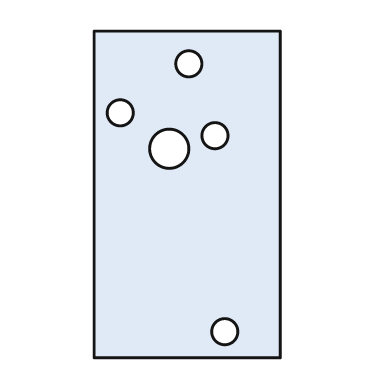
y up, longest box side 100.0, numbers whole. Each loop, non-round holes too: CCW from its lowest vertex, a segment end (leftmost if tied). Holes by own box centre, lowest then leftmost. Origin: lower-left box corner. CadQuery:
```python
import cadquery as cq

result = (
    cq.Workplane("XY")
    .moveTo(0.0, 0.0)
    .lineTo(57.0, 0.0)
    .lineTo(57.0, 100.0)
    .lineTo(0.0, 100.0)
    .close()
    .moveTo(40.0, 8.0)
    .circle(4.0)
    .moveTo(23.0, 64.0)
    .circle(6.0)
    .moveTo(37.0, 68.0)
    .circle(4.0)
    .moveTo(8.0, 75.0)
    .circle(4.0)
    .moveTo(29.0, 90.0)
    .circle(4.0)
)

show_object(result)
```